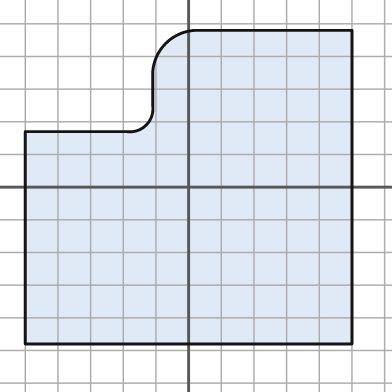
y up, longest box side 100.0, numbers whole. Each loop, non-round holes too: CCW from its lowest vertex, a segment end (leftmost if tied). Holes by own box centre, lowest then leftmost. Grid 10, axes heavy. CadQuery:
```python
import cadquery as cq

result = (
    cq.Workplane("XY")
    .moveTo(-50.0, -48.0)
    .lineTo(50.0, -48.0)
    .lineTo(50.0, 48.0)
    .lineTo(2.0, 48.0)
    .threePointArc((-7.0, 44.0), (-11.0, 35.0))
    .lineTo(-11.0, 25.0)
    .threePointArc((-13.0, 19.0), (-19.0, 17.0))
    .lineTo(-50.0, 17.0)
    .close()
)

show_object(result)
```